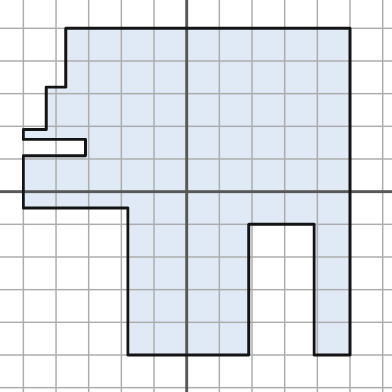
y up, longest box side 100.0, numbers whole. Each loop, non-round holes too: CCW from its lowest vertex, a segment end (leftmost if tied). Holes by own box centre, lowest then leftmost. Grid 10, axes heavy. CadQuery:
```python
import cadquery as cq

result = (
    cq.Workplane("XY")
    .moveTo(-18.0, -50.0)
    .lineTo(19.0, -50.0)
    .lineTo(19.0, -10.0)
    .lineTo(39.0, -10.0)
    .lineTo(39.0, -50.0)
    .lineTo(50.0, -50.0)
    .lineTo(50.0, 50.0)
    .lineTo(-37.0, 50.0)
    .lineTo(-37.0, 32.0)
    .lineTo(-43.0, 32.0)
    .lineTo(-43.0, 19.0)
    .lineTo(-50.0, 19.0)
    .lineTo(-50.0, 16.0)
    .lineTo(-31.0, 16.0)
    .lineTo(-31.0, 11.0)
    .lineTo(-50.0, 11.0)
    .lineTo(-50.0, -5.0)
    .lineTo(-18.0, -5.0)
    .close()
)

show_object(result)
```